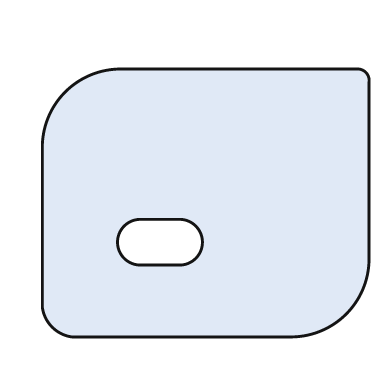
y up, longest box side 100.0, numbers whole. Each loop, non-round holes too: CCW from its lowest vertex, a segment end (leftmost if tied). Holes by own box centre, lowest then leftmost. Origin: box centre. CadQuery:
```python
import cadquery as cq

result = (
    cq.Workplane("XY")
    .moveTo(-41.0, -41.0)
    .lineTo(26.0, -41.0)
    .threePointArc((43.0, -34.0), (50.0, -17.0))
    .lineTo(50.0, 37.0)
    .threePointArc((49.0, 40.0), (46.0, 41.0))
    .lineTo(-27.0, 41.0)
    .threePointArc((-43.0, 34.0), (-50.0, 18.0))
    .lineTo(-50.0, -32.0)
    .threePointArc((-47.0, -38.0), (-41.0, -41.0))
    .close()
    .moveTo(-20.0, -19.0)
    .lineTo(-8.0, -19.0)
    .threePointArc((-1.0, -12.0), (-8.0, -5.0))
    .lineTo(-20.0, -5.0)
    .threePointArc((-27.0, -12.0), (-20.0, -19.0))
    .close()
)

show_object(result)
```